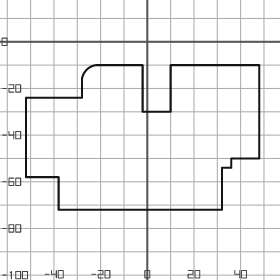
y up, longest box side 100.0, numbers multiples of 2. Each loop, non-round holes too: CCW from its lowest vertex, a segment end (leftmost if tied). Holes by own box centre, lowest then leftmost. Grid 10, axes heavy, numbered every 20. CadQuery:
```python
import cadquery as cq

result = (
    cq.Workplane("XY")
    .moveTo(-38.0, -72.0)
    .lineTo(32.0, -72.0)
    .lineTo(32.0, -54.0)
    .lineTo(36.0, -54.0)
    .lineTo(36.0, -50.0)
    .lineTo(48.0, -50.0)
    .lineTo(48.0, -10.0)
    .lineTo(10.0, -10.0)
    .lineTo(10.0, -30.0)
    .lineTo(-2.0, -30.0)
    .lineTo(-2.0, -10.0)
    .lineTo(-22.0, -10.0)
    .threePointArc((-26.0, -12.0), (-28.0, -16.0))
    .lineTo(-28.0, -24.0)
    .lineTo(-52.0, -24.0)
    .lineTo(-52.0, -58.0)
    .lineTo(-38.0, -58.0)
    .close()
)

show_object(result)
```